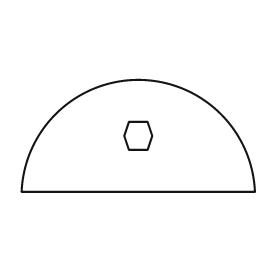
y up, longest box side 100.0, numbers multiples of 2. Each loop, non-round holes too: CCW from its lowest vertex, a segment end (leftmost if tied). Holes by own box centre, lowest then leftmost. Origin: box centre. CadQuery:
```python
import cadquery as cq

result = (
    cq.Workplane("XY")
    .moveTo(-50.0, -24.0)
    .lineTo(50.0, -24.0)
    .threePointArc((0.0, 24.0), (-50.0, -24.0))
    .close()
    .moveTo(-4.0, -6.0)
    .lineTo(4.0, -6.0)
    .lineTo(6.0, 0.0)
    .lineTo(4.0, 6.0)
    .lineTo(-4.0, 6.0)
    .lineTo(-6.0, 0.0)
    .close()
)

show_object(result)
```